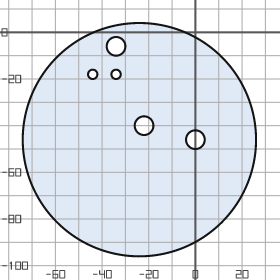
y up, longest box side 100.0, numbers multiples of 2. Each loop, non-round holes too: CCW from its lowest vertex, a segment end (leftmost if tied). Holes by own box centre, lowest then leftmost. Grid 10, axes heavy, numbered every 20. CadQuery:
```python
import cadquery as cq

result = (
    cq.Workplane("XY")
    .moveTo(-24.0, -46.0)
    .circle(50.0)
    .moveTo(0.0, -46.0)
    .circle(4.0)
    .moveTo(-22.0, -40.0)
    .circle(4.0)
    .moveTo(-44.0, -18.0)
    .circle(2.0)
    .moveTo(-34.0, -18.0)
    .circle(2.0)
    .moveTo(-34.0, -6.0)
    .circle(4.0)
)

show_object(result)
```